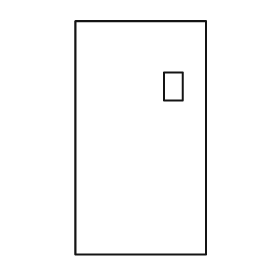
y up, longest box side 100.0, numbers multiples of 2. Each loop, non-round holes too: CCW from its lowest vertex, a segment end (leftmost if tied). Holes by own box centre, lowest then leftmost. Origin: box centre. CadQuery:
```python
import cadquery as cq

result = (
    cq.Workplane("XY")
    .moveTo(-28.0, -50.0)
    .lineTo(28.0, -50.0)
    .lineTo(28.0, 50.0)
    .lineTo(-28.0, 50.0)
    .close()
    .moveTo(10.0, 16.0)
    .lineTo(18.0, 16.0)
    .lineTo(18.0, 28.0)
    .lineTo(10.0, 28.0)
    .close()
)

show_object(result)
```